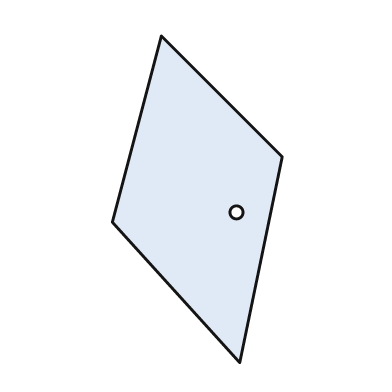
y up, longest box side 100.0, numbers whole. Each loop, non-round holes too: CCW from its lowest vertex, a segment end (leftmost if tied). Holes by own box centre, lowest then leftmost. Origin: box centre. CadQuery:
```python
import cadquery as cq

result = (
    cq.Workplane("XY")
    .moveTo(13.0, -50.0)
    .lineTo(26.0, 13.0)
    .lineTo(-11.0, 50.0)
    .lineTo(-26.0, -7.0)
    .close()
    .moveTo(12.0, -4.0)
    .circle(2.0)
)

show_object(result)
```